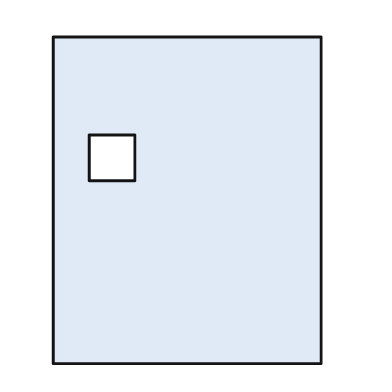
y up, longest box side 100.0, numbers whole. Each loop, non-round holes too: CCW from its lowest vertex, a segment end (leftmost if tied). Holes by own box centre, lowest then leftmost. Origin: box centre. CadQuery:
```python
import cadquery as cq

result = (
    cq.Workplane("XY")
    .moveTo(-41.0, -50.0)
    .lineTo(41.0, -50.0)
    .lineTo(41.0, 50.0)
    .lineTo(-41.0, 50.0)
    .close()
    .moveTo(-30.0, 6.0)
    .lineTo(-16.0, 6.0)
    .lineTo(-16.0, 20.0)
    .lineTo(-30.0, 20.0)
    .close()
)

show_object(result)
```